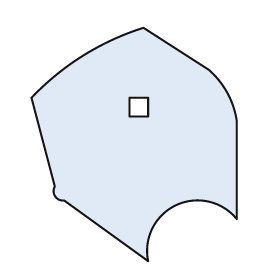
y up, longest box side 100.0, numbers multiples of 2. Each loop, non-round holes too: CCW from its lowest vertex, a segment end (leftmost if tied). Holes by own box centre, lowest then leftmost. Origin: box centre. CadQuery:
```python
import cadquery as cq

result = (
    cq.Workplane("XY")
    .moveTo(6.0, -50.0)
    .threePointArc((18.0, -26.0), (44.0, -32.0))
    .lineTo(44.0, 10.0)
    .threePointArc((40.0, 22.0), (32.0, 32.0))
    .lineTo(4.0, 50.0)
    .threePointArc((-22.0, 38.0), (-44.0, 20.0))
    .lineTo(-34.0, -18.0)
    .threePointArc((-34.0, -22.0), (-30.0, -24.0))
    .close()
    .moveTo(-2.0, 12.0)
    .lineTo(6.0, 12.0)
    .lineTo(6.0, 20.0)
    .lineTo(-2.0, 20.0)
    .close()
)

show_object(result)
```